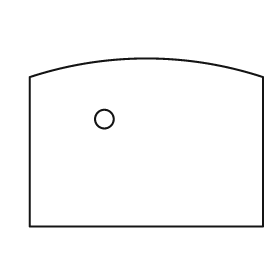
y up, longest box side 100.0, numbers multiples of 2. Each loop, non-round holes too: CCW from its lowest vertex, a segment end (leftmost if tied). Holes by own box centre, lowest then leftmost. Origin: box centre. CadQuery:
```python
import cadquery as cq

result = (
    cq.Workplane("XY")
    .moveTo(-50.0, -36.0)
    .lineTo(50.0, -36.0)
    .lineTo(50.0, 28.0)
    .threePointArc((0.0, 36.0), (-50.0, 28.0))
    .close()
    .moveTo(-18.0, 10.0)
    .circle(4.0)
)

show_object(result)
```